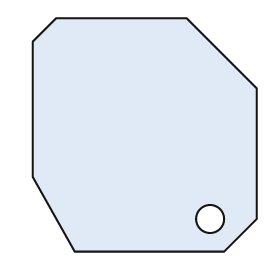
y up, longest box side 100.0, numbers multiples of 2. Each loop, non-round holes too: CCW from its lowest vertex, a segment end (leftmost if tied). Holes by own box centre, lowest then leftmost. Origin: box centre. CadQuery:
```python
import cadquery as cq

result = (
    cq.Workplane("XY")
    .moveTo(-30.0, -50.0)
    .lineTo(34.0, -50.0)
    .lineTo(48.0, -36.0)
    .lineTo(48.0, 20.0)
    .lineTo(18.0, 50.0)
    .lineTo(-38.0, 50.0)
    .lineTo(-48.0, 40.0)
    .lineTo(-48.0, -18.0)
    .close()
    .moveTo(28.0, -36.0)
    .circle(6.0)
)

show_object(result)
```